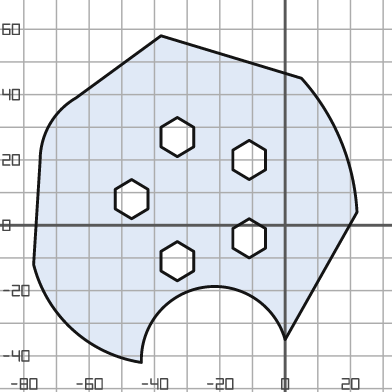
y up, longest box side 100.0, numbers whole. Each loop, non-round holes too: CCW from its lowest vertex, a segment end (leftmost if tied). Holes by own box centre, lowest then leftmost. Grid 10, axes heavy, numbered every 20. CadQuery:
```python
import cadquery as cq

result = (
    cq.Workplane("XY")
    .moveTo(-44.0, -42.0)
    .threePointArc((-25.0, -19.0), (0.0, -35.0))
    .lineTo(22.0, 4.0)
    .threePointArc((17.0, 26.0), (5.0, 45.0))
    .lineTo(-38.0, 58.0)
    .lineTo(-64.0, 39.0)
    .threePointArc((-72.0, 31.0), (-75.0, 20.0))
    .lineTo(-77.0, -12.0)
    .threePointArc((-65.0, -32.0), (-44.0, -42.0))
    .close()
    .moveTo(-33.0, -17.0)
    .lineTo(-28.0, -14.0)
    .lineTo(-28.0, -8.0)
    .lineTo(-33.0, -5.0)
    .lineTo(-38.0, -8.0)
    .lineTo(-38.0, -14.0)
    .close()
    .moveTo(-11.0, -10.0)
    .lineTo(-6.0, -7.0)
    .lineTo(-6.0, -1.0)
    .lineTo(-11.0, 2.0)
    .lineTo(-16.0, -1.0)
    .lineTo(-16.0, -7.0)
    .close()
    .moveTo(-47.0, 2.0)
    .lineTo(-42.0, 5.0)
    .lineTo(-42.0, 11.0)
    .lineTo(-47.0, 14.0)
    .lineTo(-52.0, 11.0)
    .lineTo(-52.0, 5.0)
    .close()
    .moveTo(-11.0, 14.0)
    .lineTo(-6.0, 17.0)
    .lineTo(-6.0, 23.0)
    .lineTo(-11.0, 26.0)
    .lineTo(-16.0, 23.0)
    .lineTo(-16.0, 17.0)
    .close()
    .moveTo(-33.0, 21.0)
    .lineTo(-28.0, 24.0)
    .lineTo(-28.0, 30.0)
    .lineTo(-33.0, 33.0)
    .lineTo(-38.0, 30.0)
    .lineTo(-38.0, 24.0)
    .close()
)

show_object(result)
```